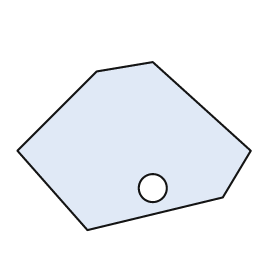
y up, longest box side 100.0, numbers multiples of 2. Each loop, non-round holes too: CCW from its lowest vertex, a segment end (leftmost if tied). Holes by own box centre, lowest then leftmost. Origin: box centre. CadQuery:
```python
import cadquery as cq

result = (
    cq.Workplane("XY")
    .moveTo(-20.0, -36.0)
    .lineTo(38.0, -22.0)
    .lineTo(50.0, -2.0)
    .lineTo(8.0, 36.0)
    .lineTo(-16.0, 32.0)
    .lineTo(-50.0, -2.0)
    .close()
    .moveTo(8.0, -18.0)
    .circle(6.0)
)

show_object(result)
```